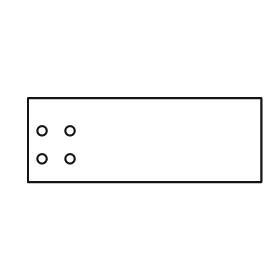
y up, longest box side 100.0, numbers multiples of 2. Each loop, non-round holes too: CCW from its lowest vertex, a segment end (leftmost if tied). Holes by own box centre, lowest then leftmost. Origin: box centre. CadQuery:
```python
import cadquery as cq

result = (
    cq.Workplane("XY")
    .moveTo(-50.0, -18.0)
    .lineTo(50.0, -18.0)
    .lineTo(50.0, 18.0)
    .lineTo(-50.0, 18.0)
    .close()
    .moveTo(-44.0, -8.0)
    .circle(2.0)
    .moveTo(-32.0, -8.0)
    .circle(2.0)
    .moveTo(-44.0, 4.0)
    .circle(2.0)
    .moveTo(-32.0, 4.0)
    .circle(2.0)
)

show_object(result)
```